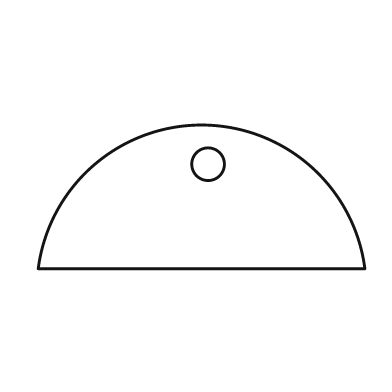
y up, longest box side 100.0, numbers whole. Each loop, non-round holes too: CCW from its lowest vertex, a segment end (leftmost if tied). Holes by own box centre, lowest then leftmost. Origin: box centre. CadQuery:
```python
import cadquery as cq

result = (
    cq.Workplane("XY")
    .moveTo(-50.0, -22.0)
    .lineTo(50.0, -22.0)
    .threePointArc((0.0, 22.0), (-50.0, -22.0))
    .close()
    .moveTo(2.0, 10.0)
    .circle(5.0)
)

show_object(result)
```